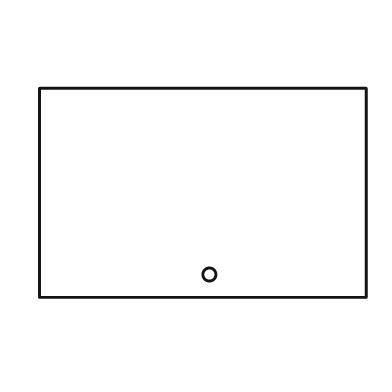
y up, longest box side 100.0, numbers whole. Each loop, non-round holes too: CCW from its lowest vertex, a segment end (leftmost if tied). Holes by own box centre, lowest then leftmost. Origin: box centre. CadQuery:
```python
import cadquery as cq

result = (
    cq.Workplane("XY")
    .moveTo(-50.0, -32.0)
    .lineTo(50.0, -32.0)
    .lineTo(50.0, 32.0)
    .lineTo(-50.0, 32.0)
    .close()
    .moveTo(2.0, -25.0)
    .circle(2.0)
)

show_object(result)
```